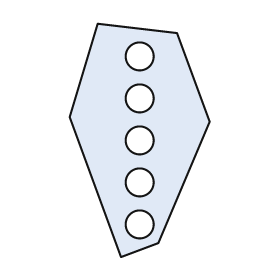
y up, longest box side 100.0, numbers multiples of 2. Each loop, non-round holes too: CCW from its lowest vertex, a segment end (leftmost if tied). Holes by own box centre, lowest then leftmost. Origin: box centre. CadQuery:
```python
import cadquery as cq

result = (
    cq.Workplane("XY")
    .moveTo(-8.0, -50.0)
    .lineTo(8.0, -44.0)
    .lineTo(30.0, 8.0)
    .lineTo(16.0, 46.0)
    .lineTo(-18.0, 50.0)
    .lineTo(-30.0, 10.0)
    .close()
    .moveTo(0.0, -36.0)
    .circle(6.0)
    .moveTo(0.0, -18.0)
    .circle(6.0)
    .moveTo(0.0, 0.0)
    .circle(6.0)
    .moveTo(0.0, 18.0)
    .circle(6.0)
    .moveTo(0.0, 36.0)
    .circle(6.0)
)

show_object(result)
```